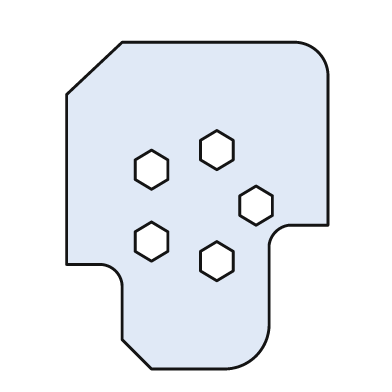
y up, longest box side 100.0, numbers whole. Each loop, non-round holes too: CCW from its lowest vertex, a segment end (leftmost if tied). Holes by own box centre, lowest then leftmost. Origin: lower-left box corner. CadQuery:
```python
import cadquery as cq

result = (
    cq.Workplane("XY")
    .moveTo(26.0, 0.0)
    .lineTo(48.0, 0.0)
    .threePointArc((58.0, 4.0), (62.0, 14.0))
    .lineTo(62.0, 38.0)
    .threePointArc((64.0, 42.0), (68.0, 44.0))
    .lineTo(80.0, 44.0)
    .lineTo(80.0, 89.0)
    .threePointArc((77.0, 97.0), (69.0, 100.0))
    .lineTo(17.0, 100.0)
    .lineTo(0.0, 84.0)
    .lineTo(0.0, 32.0)
    .lineTo(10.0, 32.0)
    .threePointArc((15.0, 30.0), (17.0, 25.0))
    .lineTo(17.0, 9.0)
    .close()
    .moveTo(46.0, 27.0)
    .lineTo(51.0, 30.0)
    .lineTo(51.0, 36.0)
    .lineTo(46.0, 39.0)
    .lineTo(41.0, 36.0)
    .lineTo(41.0, 30.0)
    .close()
    .moveTo(26.0, 33.0)
    .lineTo(31.0, 36.0)
    .lineTo(31.0, 42.0)
    .lineTo(26.0, 45.0)
    .lineTo(21.0, 42.0)
    .lineTo(21.0, 36.0)
    .close()
    .moveTo(58.0, 44.0)
    .lineTo(63.0, 47.0)
    .lineTo(63.0, 53.0)
    .lineTo(58.0, 56.0)
    .lineTo(53.0, 53.0)
    .lineTo(53.0, 47.0)
    .close()
    .moveTo(26.0, 55.0)
    .lineTo(31.0, 58.0)
    .lineTo(31.0, 64.0)
    .lineTo(26.0, 67.0)
    .lineTo(21.0, 64.0)
    .lineTo(21.0, 58.0)
    .close()
    .moveTo(46.0, 61.0)
    .lineTo(51.0, 64.0)
    .lineTo(51.0, 70.0)
    .lineTo(46.0, 73.0)
    .lineTo(41.0, 70.0)
    .lineTo(41.0, 64.0)
    .close()
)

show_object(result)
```